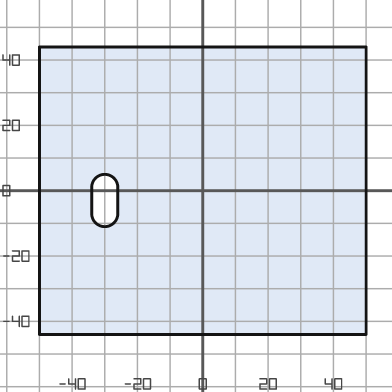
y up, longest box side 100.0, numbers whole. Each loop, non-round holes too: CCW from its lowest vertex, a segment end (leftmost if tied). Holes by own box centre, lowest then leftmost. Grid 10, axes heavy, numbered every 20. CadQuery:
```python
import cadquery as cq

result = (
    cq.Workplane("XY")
    .moveTo(-50.0, -44.0)
    .lineTo(50.0, -44.0)
    .lineTo(50.0, 44.0)
    .lineTo(-50.0, 44.0)
    .close()
    .moveTo(-34.0, -7.0)
    .threePointArc((-30.0, -11.0), (-26.0, -7.0))
    .lineTo(-26.0, 1.0)
    .threePointArc((-30.0, 5.0), (-34.0, 1.0))
    .close()
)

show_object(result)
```